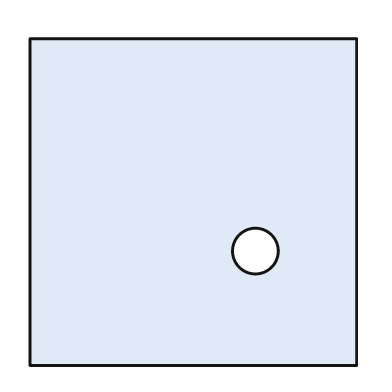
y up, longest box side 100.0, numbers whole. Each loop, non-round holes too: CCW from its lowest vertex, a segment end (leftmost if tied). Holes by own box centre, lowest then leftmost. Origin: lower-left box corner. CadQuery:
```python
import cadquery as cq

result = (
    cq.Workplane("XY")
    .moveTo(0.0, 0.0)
    .lineTo(100.0, 0.0)
    .lineTo(100.0, 100.0)
    .lineTo(0.0, 100.0)
    .close()
    .moveTo(69.0, 35.0)
    .circle(7.0)
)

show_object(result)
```